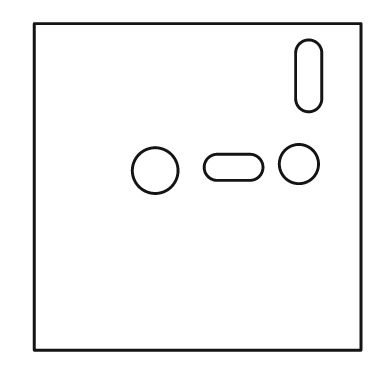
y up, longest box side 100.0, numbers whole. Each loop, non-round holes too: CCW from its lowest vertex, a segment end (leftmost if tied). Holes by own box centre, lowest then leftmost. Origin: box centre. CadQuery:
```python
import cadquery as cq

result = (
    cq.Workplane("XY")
    .moveTo(-50.0, -50.0)
    .lineTo(50.0, -50.0)
    .lineTo(50.0, 50.0)
    .lineTo(-50.0, 50.0)
    .close()
    .moveTo(-13.0, 5.0)
    .circle(7.0)
    .moveTo(6.0, 2.0)
    .lineTo(16.0, 2.0)
    .threePointArc((20.0, 6.0), (16.0, 10.0))
    .lineTo(6.0, 10.0)
    .threePointArc((2.0, 6.0), (6.0, 2.0))
    .close()
    .moveTo(31.0, 7.0)
    .circle(6.0)
    .moveTo(30.0, 27.0)
    .threePointArc((34.0, 23.0), (38.0, 27.0))
    .lineTo(38.0, 41.0)
    .threePointArc((34.0, 45.0), (30.0, 41.0))
    .close()
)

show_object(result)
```